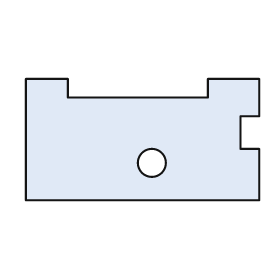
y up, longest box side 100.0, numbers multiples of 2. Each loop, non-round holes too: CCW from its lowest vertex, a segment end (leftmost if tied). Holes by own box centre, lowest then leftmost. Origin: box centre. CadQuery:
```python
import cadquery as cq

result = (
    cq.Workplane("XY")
    .moveTo(-50.0, -26.0)
    .lineTo(50.0, -26.0)
    .lineTo(50.0, -4.0)
    .lineTo(42.0, -4.0)
    .lineTo(42.0, 10.0)
    .lineTo(50.0, 10.0)
    .lineTo(50.0, 26.0)
    .lineTo(28.0, 26.0)
    .lineTo(28.0, 18.0)
    .lineTo(-32.0, 18.0)
    .lineTo(-32.0, 26.0)
    .lineTo(-50.0, 26.0)
    .close()
    .moveTo(4.0, -10.0)
    .circle(6.0)
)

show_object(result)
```